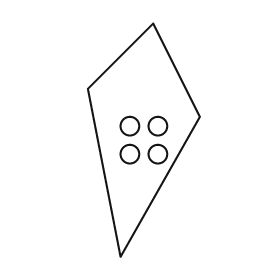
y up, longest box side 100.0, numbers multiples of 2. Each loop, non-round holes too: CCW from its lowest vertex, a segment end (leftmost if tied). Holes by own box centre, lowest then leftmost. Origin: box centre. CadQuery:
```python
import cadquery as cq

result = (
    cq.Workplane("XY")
    .moveTo(-10.0, -50.0)
    .lineTo(24.0, 10.0)
    .lineTo(4.0, 50.0)
    .lineTo(-24.0, 22.0)
    .close()
    .moveTo(-6.0, -6.0)
    .circle(4.0)
    .moveTo(6.0, -6.0)
    .circle(4.0)
    .moveTo(-6.0, 6.0)
    .circle(4.0)
    .moveTo(6.0, 6.0)
    .circle(4.0)
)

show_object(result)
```